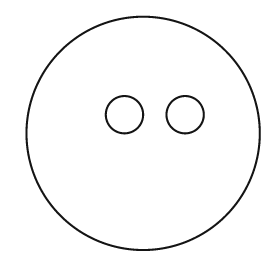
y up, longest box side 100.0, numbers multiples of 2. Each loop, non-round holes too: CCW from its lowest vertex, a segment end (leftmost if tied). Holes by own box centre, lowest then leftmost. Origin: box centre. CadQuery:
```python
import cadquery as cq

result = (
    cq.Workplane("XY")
    .moveTo(0.0, 0.0)
    .circle(50.0)
    .moveTo(-8.0, 8.0)
    .circle(8.0)
    .moveTo(18.0, 8.0)
    .circle(8.0)
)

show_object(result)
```